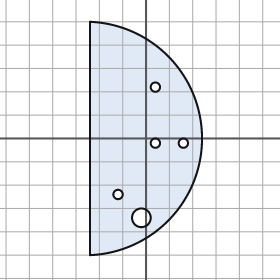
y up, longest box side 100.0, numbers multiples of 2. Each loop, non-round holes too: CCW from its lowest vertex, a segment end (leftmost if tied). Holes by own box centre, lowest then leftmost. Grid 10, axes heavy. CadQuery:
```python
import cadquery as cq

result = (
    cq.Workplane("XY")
    .moveTo(-24.0, -50.0)
    .threePointArc((24.0, 0.0), (-24.0, 50.0))
    .close()
    .moveTo(-2.0, -34.0)
    .circle(4.0)
    .moveTo(-12.0, -24.0)
    .circle(2.0)
    .moveTo(4.0, -2.0)
    .circle(2.0)
    .moveTo(16.0, -2.0)
    .circle(2.0)
    .moveTo(4.0, 22.0)
    .circle(2.0)
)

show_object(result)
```